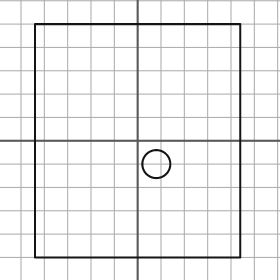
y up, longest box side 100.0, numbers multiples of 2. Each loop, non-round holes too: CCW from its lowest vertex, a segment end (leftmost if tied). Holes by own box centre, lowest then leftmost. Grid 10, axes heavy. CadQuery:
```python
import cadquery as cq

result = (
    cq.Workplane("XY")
    .moveTo(-44.0, -50.0)
    .lineTo(44.0, -50.0)
    .lineTo(44.0, 50.0)
    .lineTo(-44.0, 50.0)
    .close()
    .moveTo(8.0, -10.0)
    .circle(6.0)
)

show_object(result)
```